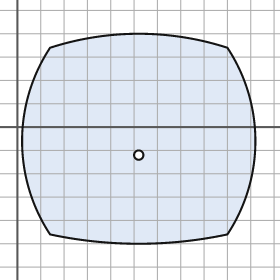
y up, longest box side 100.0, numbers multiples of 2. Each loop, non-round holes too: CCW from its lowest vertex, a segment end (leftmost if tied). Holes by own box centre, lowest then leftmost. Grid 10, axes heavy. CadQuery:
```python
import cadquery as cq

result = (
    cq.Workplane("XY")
    .moveTo(14.0, -46.0)
    .threePointArc((52.0, -50.0), (90.0, -46.0))
    .threePointArc((102.0, -6.0), (90.0, 34.0))
    .threePointArc((52.0, 40.0), (14.0, 34.0))
    .threePointArc((2.0, -6.0), (14.0, -46.0))
    .close()
    .moveTo(52.0, -12.0)
    .circle(2.0)
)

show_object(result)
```